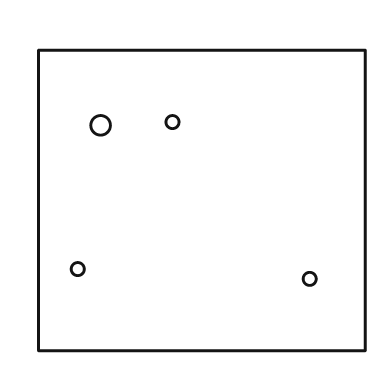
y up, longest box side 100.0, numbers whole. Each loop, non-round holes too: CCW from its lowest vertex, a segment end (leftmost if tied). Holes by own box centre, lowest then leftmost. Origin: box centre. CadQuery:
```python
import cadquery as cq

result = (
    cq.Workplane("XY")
    .moveTo(-50.0, -46.0)
    .lineTo(50.0, -46.0)
    .lineTo(50.0, 46.0)
    .lineTo(-50.0, 46.0)
    .close()
    .moveTo(33.0, -24.0)
    .circle(2.0)
    .moveTo(-38.0, -21.0)
    .circle(2.0)
    .moveTo(-31.0, 23.0)
    .circle(3.0)
    .moveTo(-9.0, 24.0)
    .circle(2.0)
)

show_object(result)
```